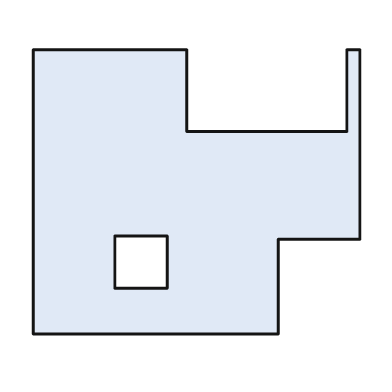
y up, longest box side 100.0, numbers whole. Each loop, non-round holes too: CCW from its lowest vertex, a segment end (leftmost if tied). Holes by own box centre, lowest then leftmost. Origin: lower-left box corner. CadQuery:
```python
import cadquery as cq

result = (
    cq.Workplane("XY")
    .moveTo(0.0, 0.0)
    .lineTo(75.0, 0.0)
    .lineTo(75.0, 29.0)
    .lineTo(100.0, 29.0)
    .lineTo(100.0, 87.0)
    .lineTo(96.0, 87.0)
    .lineTo(96.0, 62.0)
    .lineTo(47.0, 62.0)
    .lineTo(47.0, 87.0)
    .lineTo(0.0, 87.0)
    .close()
    .moveTo(25.0, 14.0)
    .lineTo(41.0, 14.0)
    .lineTo(41.0, 30.0)
    .lineTo(25.0, 30.0)
    .close()
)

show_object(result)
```